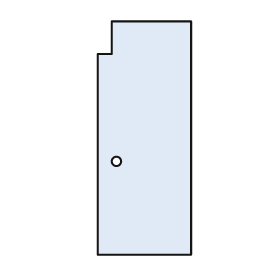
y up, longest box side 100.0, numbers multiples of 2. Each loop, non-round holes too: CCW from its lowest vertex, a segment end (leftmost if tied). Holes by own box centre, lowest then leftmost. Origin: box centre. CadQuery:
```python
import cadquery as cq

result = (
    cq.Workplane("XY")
    .moveTo(-20.0, -50.0)
    .lineTo(20.0, -50.0)
    .lineTo(20.0, 50.0)
    .lineTo(-14.0, 50.0)
    .lineTo(-14.0, 36.0)
    .lineTo(-20.0, 36.0)
    .close()
    .moveTo(-12.0, -10.0)
    .circle(2.0)
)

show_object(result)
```